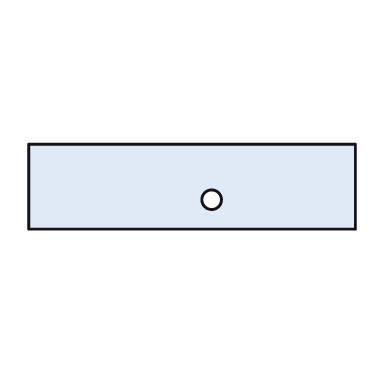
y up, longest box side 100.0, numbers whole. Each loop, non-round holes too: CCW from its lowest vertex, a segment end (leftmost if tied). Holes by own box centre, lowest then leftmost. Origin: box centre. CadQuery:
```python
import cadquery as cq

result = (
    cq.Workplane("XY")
    .moveTo(-50.0, -13.0)
    .lineTo(50.0, -13.0)
    .lineTo(50.0, 13.0)
    .lineTo(-50.0, 13.0)
    .close()
    .moveTo(6.0, -4.0)
    .circle(3.0)
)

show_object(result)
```